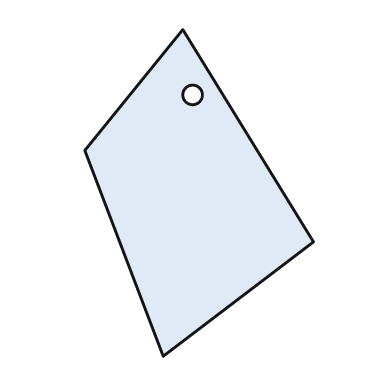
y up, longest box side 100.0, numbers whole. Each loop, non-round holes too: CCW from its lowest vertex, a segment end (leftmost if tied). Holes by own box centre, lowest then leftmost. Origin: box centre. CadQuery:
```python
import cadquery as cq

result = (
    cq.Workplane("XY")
    .moveTo(-11.0, -50.0)
    .lineTo(35.0, -15.0)
    .lineTo(-5.0, 50.0)
    .lineTo(-35.0, 13.0)
    .close()
    .moveTo(-2.0, 30.0)
    .circle(3.0)
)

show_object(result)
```